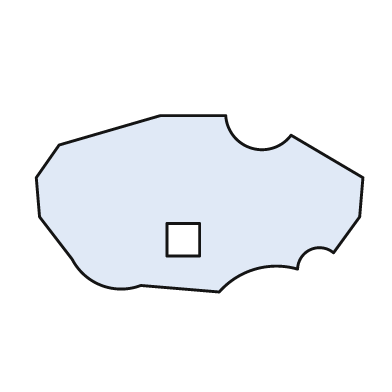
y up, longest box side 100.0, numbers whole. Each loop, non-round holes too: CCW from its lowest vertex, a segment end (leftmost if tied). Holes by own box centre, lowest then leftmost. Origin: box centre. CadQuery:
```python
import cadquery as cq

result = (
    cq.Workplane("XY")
    .moveTo(6.0, -27.0)
    .threePointArc((17.0, -20.0), (30.0, -20.0))
    .threePointArc((34.0, -14.0), (41.0, -15.0))
    .lineTo(49.0, -4.0)
    .lineTo(50.0, 8.0)
    .lineTo(28.0, 21.0)
    .threePointArc((16.0, 17.0), (8.0, 27.0))
    .lineTo(-12.0, 27.0)
    .lineTo(-43.0, 18.0)
    .lineTo(-50.0, 8.0)
    .lineTo(-49.0, -4.0)
    .lineTo(-39.0, -17.0)
    .threePointArc((-30.0, -25.0), (-18.0, -25.0))
    .close()
    .moveTo(-10.0, -16.0)
    .lineTo(0.0, -16.0)
    .lineTo(0.0, -6.0)
    .lineTo(-10.0, -6.0)
    .close()
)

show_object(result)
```